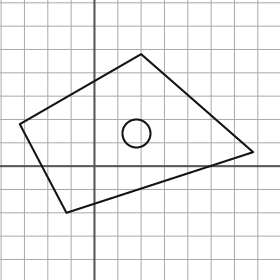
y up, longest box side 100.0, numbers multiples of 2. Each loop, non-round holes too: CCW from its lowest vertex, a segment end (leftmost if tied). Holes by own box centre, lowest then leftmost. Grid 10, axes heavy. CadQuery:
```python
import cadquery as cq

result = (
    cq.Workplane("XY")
    .moveTo(-12.0, -20.0)
    .lineTo(68.0, 6.0)
    .lineTo(20.0, 48.0)
    .lineTo(-32.0, 18.0)
    .close()
    .moveTo(18.0, 14.0)
    .circle(6.0)
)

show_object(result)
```